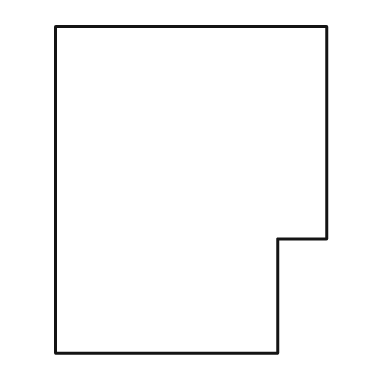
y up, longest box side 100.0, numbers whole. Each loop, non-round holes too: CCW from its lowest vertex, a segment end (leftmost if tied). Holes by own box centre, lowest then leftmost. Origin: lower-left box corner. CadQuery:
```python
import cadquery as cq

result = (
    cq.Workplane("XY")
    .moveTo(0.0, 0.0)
    .lineTo(68.0, 0.0)
    .lineTo(68.0, 35.0)
    .lineTo(83.0, 35.0)
    .lineTo(83.0, 100.0)
    .lineTo(0.0, 100.0)
    .close()
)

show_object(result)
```